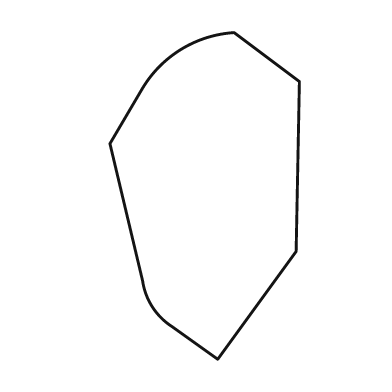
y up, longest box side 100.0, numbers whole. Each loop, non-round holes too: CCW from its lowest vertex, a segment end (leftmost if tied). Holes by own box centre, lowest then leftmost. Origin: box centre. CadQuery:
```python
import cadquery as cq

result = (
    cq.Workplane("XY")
    .moveTo(4.0, -50.0)
    .lineTo(28.0, -17.0)
    .lineTo(29.0, 35.0)
    .lineTo(9.0, 50.0)
    .threePointArc((-7.0, 45.0), (-19.0, 33.0))
    .lineTo(-29.0, 16.0)
    .lineTo(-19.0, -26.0)
    .threePointArc((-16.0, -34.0), (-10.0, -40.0))
    .close()
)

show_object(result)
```